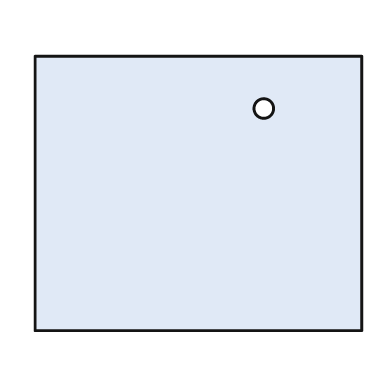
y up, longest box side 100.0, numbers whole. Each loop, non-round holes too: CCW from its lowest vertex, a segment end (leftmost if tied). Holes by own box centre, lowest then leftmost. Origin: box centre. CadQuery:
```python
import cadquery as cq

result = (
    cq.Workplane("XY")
    .moveTo(-50.0, -42.0)
    .lineTo(50.0, -42.0)
    .lineTo(50.0, 42.0)
    .lineTo(-50.0, 42.0)
    .close()
    .moveTo(20.0, 26.0)
    .circle(3.0)
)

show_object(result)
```